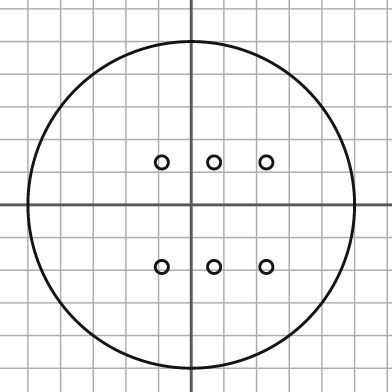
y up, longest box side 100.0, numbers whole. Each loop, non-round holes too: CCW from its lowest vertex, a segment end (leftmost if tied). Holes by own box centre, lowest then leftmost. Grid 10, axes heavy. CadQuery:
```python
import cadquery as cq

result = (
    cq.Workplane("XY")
    .moveTo(0.0, 0.0)
    .circle(50.0)
    .moveTo(-9.0, -19.0)
    .circle(2.0)
    .moveTo(7.0, -19.0)
    .circle(2.0)
    .moveTo(23.0, -19.0)
    .circle(2.0)
    .moveTo(-9.0, 13.0)
    .circle(2.0)
    .moveTo(7.0, 13.0)
    .circle(2.0)
    .moveTo(23.0, 13.0)
    .circle(2.0)
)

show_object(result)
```